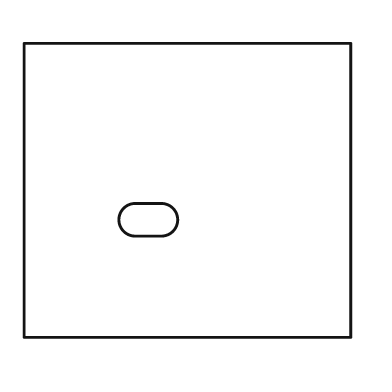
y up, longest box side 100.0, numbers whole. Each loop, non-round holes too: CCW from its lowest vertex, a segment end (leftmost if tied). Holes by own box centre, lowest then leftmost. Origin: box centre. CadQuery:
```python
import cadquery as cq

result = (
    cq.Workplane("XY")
    .moveTo(-50.0, -45.0)
    .lineTo(50.0, -45.0)
    .lineTo(50.0, 45.0)
    .lineTo(-50.0, 45.0)
    .close()
    .moveTo(-16.0, -14.0)
    .lineTo(-8.0, -14.0)
    .threePointArc((-3.0, -9.0), (-8.0, -4.0))
    .lineTo(-16.0, -4.0)
    .threePointArc((-21.0, -9.0), (-16.0, -14.0))
    .close()
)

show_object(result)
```